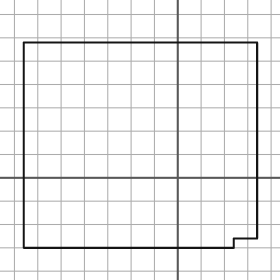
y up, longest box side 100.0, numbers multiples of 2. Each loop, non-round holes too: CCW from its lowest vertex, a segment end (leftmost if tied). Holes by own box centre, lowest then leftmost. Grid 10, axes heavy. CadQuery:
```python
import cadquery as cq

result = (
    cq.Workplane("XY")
    .moveTo(-66.0, -30.0)
    .lineTo(24.0, -30.0)
    .lineTo(24.0, -26.0)
    .lineTo(34.0, -26.0)
    .lineTo(34.0, 58.0)
    .lineTo(-66.0, 58.0)
    .close()
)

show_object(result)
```